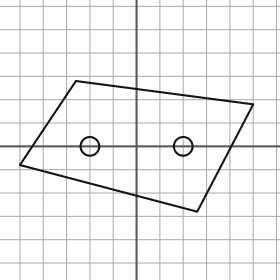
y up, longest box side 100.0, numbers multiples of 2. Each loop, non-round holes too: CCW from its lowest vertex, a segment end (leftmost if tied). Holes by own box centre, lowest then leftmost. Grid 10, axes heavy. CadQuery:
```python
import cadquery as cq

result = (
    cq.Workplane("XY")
    .moveTo(26.0, -28.0)
    .lineTo(50.0, 18.0)
    .lineTo(-26.0, 28.0)
    .lineTo(-50.0, -8.0)
    .close()
    .moveTo(-20.0, 0.0)
    .circle(4.0)
    .moveTo(20.0, 0.0)
    .circle(4.0)
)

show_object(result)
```